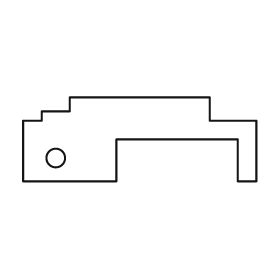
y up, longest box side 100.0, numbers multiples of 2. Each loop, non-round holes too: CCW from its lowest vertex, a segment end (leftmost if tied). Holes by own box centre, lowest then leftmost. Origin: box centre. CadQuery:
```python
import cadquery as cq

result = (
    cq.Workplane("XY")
    .moveTo(-50.0, -18.0)
    .lineTo(-10.0, -18.0)
    .lineTo(-10.0, 0.0)
    .lineTo(42.0, 0.0)
    .lineTo(42.0, -18.0)
    .lineTo(50.0, -18.0)
    .lineTo(50.0, 8.0)
    .lineTo(30.0, 8.0)
    .lineTo(30.0, 18.0)
    .lineTo(-30.0, 18.0)
    .lineTo(-30.0, 12.0)
    .lineTo(-42.0, 12.0)
    .lineTo(-42.0, 8.0)
    .lineTo(-50.0, 8.0)
    .close()
    .moveTo(-36.0, -8.0)
    .circle(4.0)
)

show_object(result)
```